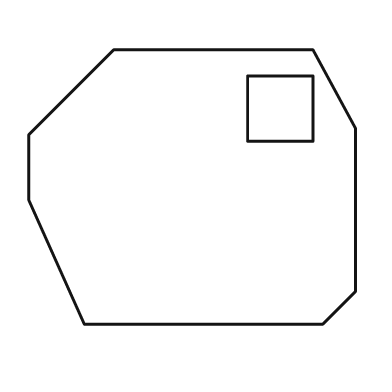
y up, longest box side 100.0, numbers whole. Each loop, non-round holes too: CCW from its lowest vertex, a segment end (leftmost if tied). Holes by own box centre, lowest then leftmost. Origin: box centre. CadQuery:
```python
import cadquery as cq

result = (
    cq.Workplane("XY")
    .moveTo(-33.0, -42.0)
    .lineTo(40.0, -42.0)
    .lineTo(50.0, -32.0)
    .lineTo(50.0, 18.0)
    .lineTo(37.0, 42.0)
    .lineTo(-24.0, 42.0)
    .lineTo(-50.0, 16.0)
    .lineTo(-50.0, -4.0)
    .close()
    .moveTo(17.0, 14.0)
    .lineTo(37.0, 14.0)
    .lineTo(37.0, 34.0)
    .lineTo(17.0, 34.0)
    .close()
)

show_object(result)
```